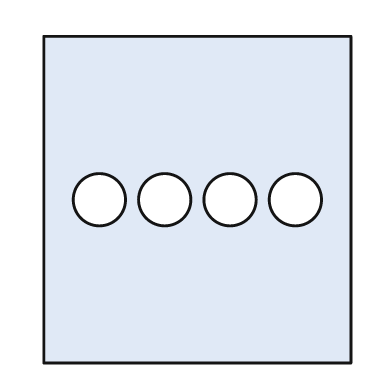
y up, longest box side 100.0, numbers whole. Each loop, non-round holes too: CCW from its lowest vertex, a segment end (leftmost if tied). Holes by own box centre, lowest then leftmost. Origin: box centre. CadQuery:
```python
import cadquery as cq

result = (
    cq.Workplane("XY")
    .moveTo(-47.0, -50.0)
    .lineTo(47.0, -50.0)
    .lineTo(47.0, 50.0)
    .lineTo(-47.0, 50.0)
    .close()
    .moveTo(-30.0, 0.0)
    .circle(8.0)
    .moveTo(-10.0, 0.0)
    .circle(8.0)
    .moveTo(10.0, 0.0)
    .circle(8.0)
    .moveTo(30.0, 0.0)
    .circle(8.0)
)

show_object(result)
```